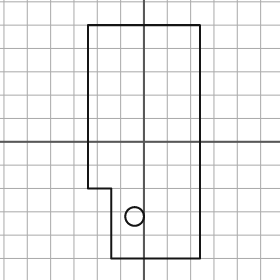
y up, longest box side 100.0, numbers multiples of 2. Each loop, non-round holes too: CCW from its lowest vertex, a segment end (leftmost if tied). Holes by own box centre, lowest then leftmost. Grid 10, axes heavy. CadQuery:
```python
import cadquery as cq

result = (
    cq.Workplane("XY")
    .moveTo(-14.0, -50.0)
    .lineTo(24.0, -50.0)
    .lineTo(24.0, 50.0)
    .lineTo(-24.0, 50.0)
    .lineTo(-24.0, -20.0)
    .lineTo(-14.0, -20.0)
    .close()
    .moveTo(-4.0, -32.0)
    .circle(4.0)
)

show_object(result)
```